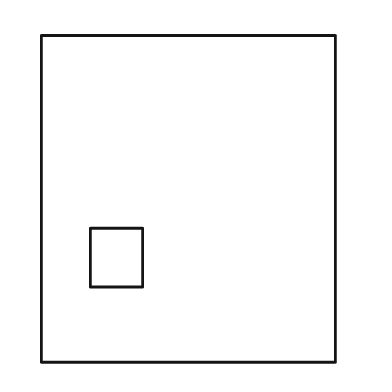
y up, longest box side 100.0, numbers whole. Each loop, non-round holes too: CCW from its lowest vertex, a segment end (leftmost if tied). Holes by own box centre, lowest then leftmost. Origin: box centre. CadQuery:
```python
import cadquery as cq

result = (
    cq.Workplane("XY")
    .moveTo(-45.0, -50.0)
    .lineTo(45.0, -50.0)
    .lineTo(45.0, 50.0)
    .lineTo(-45.0, 50.0)
    .close()
    .moveTo(-30.0, -27.0)
    .lineTo(-14.0, -27.0)
    .lineTo(-14.0, -9.0)
    .lineTo(-30.0, -9.0)
    .close()
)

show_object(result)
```